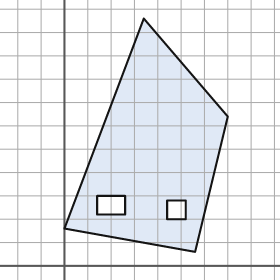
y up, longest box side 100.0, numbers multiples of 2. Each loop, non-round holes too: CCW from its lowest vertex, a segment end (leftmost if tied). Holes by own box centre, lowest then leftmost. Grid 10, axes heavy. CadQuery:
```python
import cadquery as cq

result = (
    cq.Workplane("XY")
    .moveTo(56.0, 6.0)
    .lineTo(70.0, 64.0)
    .lineTo(34.0, 106.0)
    .lineTo(0.0, 16.0)
    .close()
    .moveTo(44.0, 20.0)
    .lineTo(52.0, 20.0)
    .lineTo(52.0, 28.0)
    .lineTo(44.0, 28.0)
    .close()
    .moveTo(14.0, 22.0)
    .lineTo(26.0, 22.0)
    .lineTo(26.0, 30.0)
    .lineTo(14.0, 30.0)
    .close()
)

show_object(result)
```